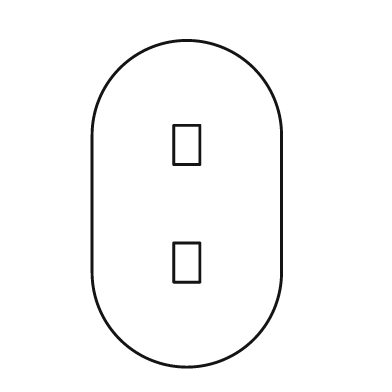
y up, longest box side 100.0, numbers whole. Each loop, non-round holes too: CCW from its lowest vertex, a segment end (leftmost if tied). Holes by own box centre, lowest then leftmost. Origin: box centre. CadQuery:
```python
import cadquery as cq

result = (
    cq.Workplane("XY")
    .moveTo(-29.0, -21.0)
    .threePointArc((0.0, -50.0), (29.0, -21.0))
    .lineTo(29.0, 21.0)
    .threePointArc((0.0, 50.0), (-29.0, 21.0))
    .close()
    .moveTo(-4.0, -24.0)
    .lineTo(4.0, -24.0)
    .lineTo(4.0, -12.0)
    .lineTo(-4.0, -12.0)
    .close()
    .moveTo(-4.0, 12.0)
    .lineTo(4.0, 12.0)
    .lineTo(4.0, 24.0)
    .lineTo(-4.0, 24.0)
    .close()
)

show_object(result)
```